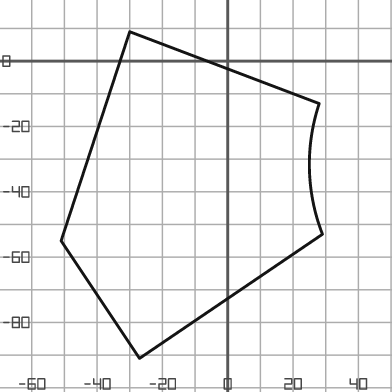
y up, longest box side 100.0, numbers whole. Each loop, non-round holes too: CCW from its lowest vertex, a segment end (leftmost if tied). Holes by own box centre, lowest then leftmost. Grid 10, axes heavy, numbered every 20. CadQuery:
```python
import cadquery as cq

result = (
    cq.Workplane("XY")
    .moveTo(-27.0, -91.0)
    .lineTo(29.0, -53.0)
    .threePointArc((25.0, -33.0), (28.0, -13.0))
    .lineTo(-30.0, 9.0)
    .lineTo(-51.0, -55.0)
    .close()
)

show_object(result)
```